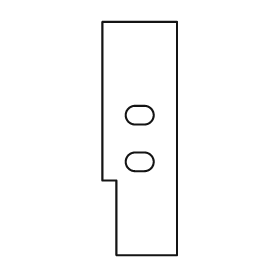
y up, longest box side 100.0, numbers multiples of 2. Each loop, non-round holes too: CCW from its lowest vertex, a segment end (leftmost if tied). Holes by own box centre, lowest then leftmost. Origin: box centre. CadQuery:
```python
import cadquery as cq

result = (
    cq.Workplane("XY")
    .moveTo(-10.0, -50.0)
    .lineTo(16.0, -50.0)
    .lineTo(16.0, 50.0)
    .lineTo(-16.0, 50.0)
    .lineTo(-16.0, -18.0)
    .lineTo(-10.0, -18.0)
    .close()
    .moveTo(-2.0, -14.0)
    .lineTo(2.0, -14.0)
    .threePointArc((6.0, -10.0), (2.0, -6.0))
    .lineTo(-2.0, -6.0)
    .threePointArc((-6.0, -10.0), (-2.0, -14.0))
    .close()
    .moveTo(-2.0, 6.0)
    .lineTo(2.0, 6.0)
    .threePointArc((6.0, 10.0), (2.0, 14.0))
    .lineTo(-2.0, 14.0)
    .threePointArc((-6.0, 10.0), (-2.0, 6.0))
    .close()
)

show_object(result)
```